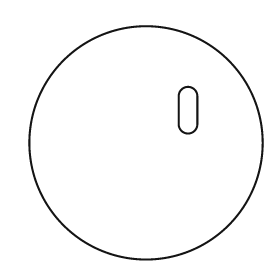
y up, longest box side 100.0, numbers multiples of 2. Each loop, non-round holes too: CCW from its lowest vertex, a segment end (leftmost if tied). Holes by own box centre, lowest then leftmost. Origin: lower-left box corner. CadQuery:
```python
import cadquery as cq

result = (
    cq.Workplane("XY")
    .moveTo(50.0, 50.0)
    .circle(50.0)
    .moveTo(64.0, 58.0)
    .threePointArc((68.0, 54.0), (72.0, 58.0))
    .lineTo(72.0, 70.0)
    .threePointArc((68.0, 74.0), (64.0, 70.0))
    .close()
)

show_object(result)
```